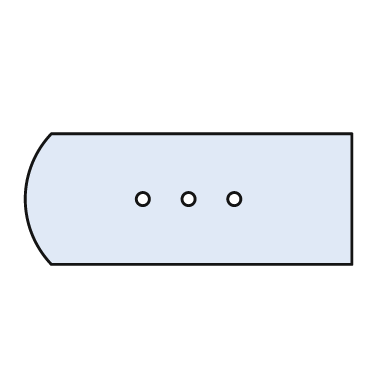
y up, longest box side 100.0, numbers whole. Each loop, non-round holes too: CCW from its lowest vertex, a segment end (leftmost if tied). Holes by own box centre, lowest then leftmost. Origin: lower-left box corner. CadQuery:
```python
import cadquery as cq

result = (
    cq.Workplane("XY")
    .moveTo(8.0, 0.0)
    .lineTo(100.0, 0.0)
    .lineTo(100.0, 40.0)
    .lineTo(8.0, 40.0)
    .threePointArc((0.0, 20.0), (8.0, 0.0))
    .close()
    .moveTo(36.0, 20.0)
    .circle(2.0)
    .moveTo(50.0, 20.0)
    .circle(2.0)
    .moveTo(64.0, 20.0)
    .circle(2.0)
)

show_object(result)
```